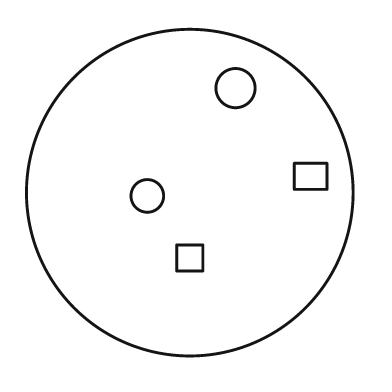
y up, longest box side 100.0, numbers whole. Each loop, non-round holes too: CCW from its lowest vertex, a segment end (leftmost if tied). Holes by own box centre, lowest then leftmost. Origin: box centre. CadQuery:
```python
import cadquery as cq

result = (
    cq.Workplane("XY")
    .moveTo(0.0, 0.0)
    .circle(50.0)
    .moveTo(-4.0, -24.0)
    .lineTo(4.0, -24.0)
    .lineTo(4.0, -16.0)
    .lineTo(-4.0, -16.0)
    .close()
    .moveTo(-13.0, -1.0)
    .circle(5.0)
    .moveTo(32.0, 1.0)
    .lineTo(42.0, 1.0)
    .lineTo(42.0, 9.0)
    .lineTo(32.0, 9.0)
    .close()
    .moveTo(14.0, 32.0)
    .circle(6.0)
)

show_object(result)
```